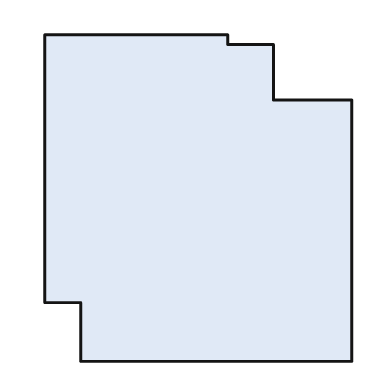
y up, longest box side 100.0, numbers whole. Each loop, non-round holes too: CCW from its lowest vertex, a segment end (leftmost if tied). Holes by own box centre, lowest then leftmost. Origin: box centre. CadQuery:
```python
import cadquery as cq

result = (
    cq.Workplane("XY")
    .moveTo(-36.0, -50.0)
    .lineTo(47.0, -50.0)
    .lineTo(47.0, 30.0)
    .lineTo(23.0, 30.0)
    .lineTo(23.0, 47.0)
    .lineTo(9.0, 47.0)
    .lineTo(9.0, 50.0)
    .lineTo(-47.0, 50.0)
    .lineTo(-47.0, -32.0)
    .lineTo(-36.0, -32.0)
    .close()
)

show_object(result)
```